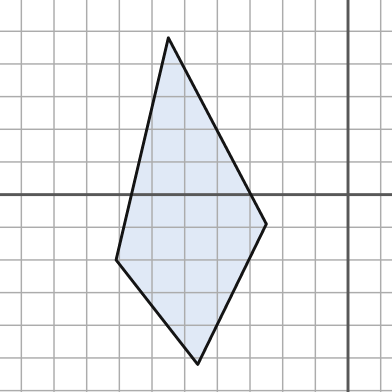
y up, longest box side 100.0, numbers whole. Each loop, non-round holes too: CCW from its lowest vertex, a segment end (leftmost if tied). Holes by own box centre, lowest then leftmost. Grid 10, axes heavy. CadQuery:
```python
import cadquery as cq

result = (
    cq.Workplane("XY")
    .moveTo(-46.0, -52.0)
    .lineTo(-25.0, -9.0)
    .lineTo(-55.0, 48.0)
    .lineTo(-71.0, -20.0)
    .close()
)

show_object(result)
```